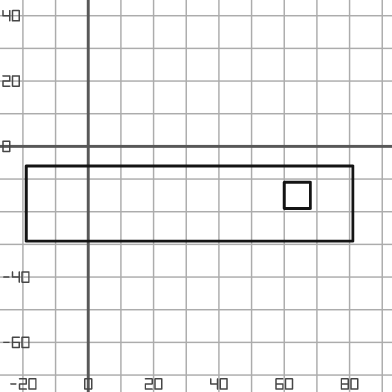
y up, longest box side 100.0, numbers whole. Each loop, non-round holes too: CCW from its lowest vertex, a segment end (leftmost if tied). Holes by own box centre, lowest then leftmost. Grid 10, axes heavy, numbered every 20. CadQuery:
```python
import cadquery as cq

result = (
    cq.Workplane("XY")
    .moveTo(-19.0, -29.0)
    .lineTo(81.0, -29.0)
    .lineTo(81.0, -6.0)
    .lineTo(-19.0, -6.0)
    .close()
    .moveTo(60.0, -19.0)
    .lineTo(68.0, -19.0)
    .lineTo(68.0, -11.0)
    .lineTo(60.0, -11.0)
    .close()
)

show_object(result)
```